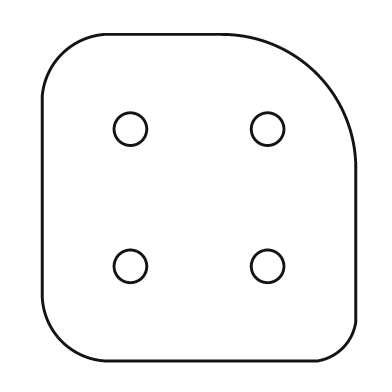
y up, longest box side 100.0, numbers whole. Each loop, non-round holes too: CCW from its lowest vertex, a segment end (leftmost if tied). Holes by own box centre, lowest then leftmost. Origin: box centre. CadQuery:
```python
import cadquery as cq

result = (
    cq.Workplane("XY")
    .moveTo(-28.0, -50.0)
    .lineTo(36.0, -50.0)
    .threePointArc((44.0, -46.0), (48.0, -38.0))
    .lineTo(48.0, 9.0)
    .threePointArc((36.0, 38.0), (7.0, 50.0))
    .lineTo(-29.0, 50.0)
    .threePointArc((-42.0, 44.0), (-48.0, 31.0))
    .lineTo(-48.0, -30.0)
    .threePointArc((-42.0, -44.0), (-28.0, -50.0))
    .close()
    .moveTo(-21.0, -21.0)
    .circle(5.0)
    .moveTo(21.0, -21.0)
    .circle(5.0)
    .moveTo(-21.0, 21.0)
    .circle(5.0)
    .moveTo(21.0, 21.0)
    .circle(5.0)
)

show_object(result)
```